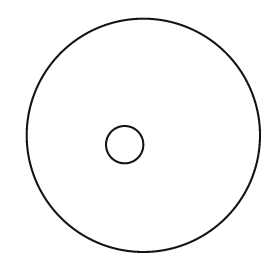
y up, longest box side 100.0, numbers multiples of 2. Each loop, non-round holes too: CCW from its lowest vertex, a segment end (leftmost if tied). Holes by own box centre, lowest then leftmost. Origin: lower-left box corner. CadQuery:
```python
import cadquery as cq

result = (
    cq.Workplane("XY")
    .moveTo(50.0, 50.0)
    .circle(50.0)
    .moveTo(42.0, 46.0)
    .circle(8.0)
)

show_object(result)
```